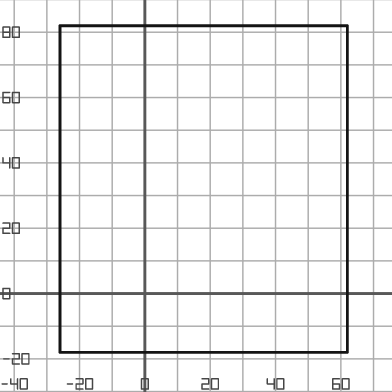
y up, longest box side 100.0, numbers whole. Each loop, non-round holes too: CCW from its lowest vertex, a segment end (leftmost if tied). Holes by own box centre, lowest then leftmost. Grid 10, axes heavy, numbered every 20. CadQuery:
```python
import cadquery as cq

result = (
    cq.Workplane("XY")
    .moveTo(-26.0, -18.0)
    .lineTo(62.0, -18.0)
    .lineTo(62.0, 82.0)
    .lineTo(-26.0, 82.0)
    .close()
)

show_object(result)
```